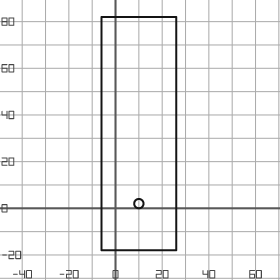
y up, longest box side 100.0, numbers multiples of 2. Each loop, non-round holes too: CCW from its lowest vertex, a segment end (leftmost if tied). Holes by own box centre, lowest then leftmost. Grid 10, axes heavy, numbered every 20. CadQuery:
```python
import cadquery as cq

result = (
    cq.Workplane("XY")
    .moveTo(-6.0, -18.0)
    .lineTo(26.0, -18.0)
    .lineTo(26.0, 82.0)
    .lineTo(-6.0, 82.0)
    .close()
    .moveTo(10.0, 2.0)
    .circle(2.0)
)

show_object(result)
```